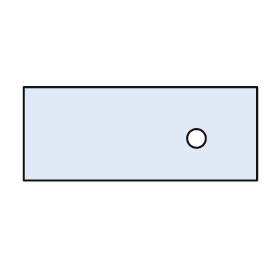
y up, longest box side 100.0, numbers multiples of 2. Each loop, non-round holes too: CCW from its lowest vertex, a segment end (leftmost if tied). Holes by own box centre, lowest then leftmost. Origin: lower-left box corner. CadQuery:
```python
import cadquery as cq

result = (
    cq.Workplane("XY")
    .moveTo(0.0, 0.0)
    .lineTo(100.0, 0.0)
    .lineTo(100.0, 40.0)
    .lineTo(0.0, 40.0)
    .close()
    .moveTo(74.0, 18.0)
    .circle(4.0)
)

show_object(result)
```